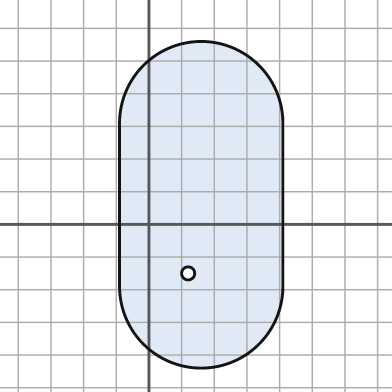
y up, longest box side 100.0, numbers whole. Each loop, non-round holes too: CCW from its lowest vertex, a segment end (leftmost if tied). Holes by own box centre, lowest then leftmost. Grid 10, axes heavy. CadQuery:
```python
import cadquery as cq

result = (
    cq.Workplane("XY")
    .moveTo(-9.0, -19.0)
    .threePointArc((16.0, -44.0), (41.0, -19.0))
    .lineTo(41.0, 31.0)
    .threePointArc((16.0, 56.0), (-9.0, 31.0))
    .close()
    .moveTo(12.0, -15.0)
    .circle(2.0)
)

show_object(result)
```